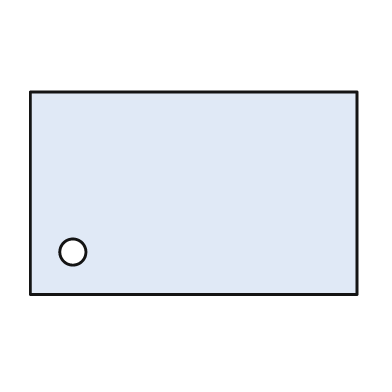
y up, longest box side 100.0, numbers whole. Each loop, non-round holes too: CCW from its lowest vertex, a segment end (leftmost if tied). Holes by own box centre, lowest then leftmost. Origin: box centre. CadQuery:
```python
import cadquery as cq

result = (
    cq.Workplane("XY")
    .moveTo(-50.0, -31.0)
    .lineTo(50.0, -31.0)
    .lineTo(50.0, 31.0)
    .lineTo(-50.0, 31.0)
    .close()
    .moveTo(-37.0, -18.0)
    .circle(4.0)
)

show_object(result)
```